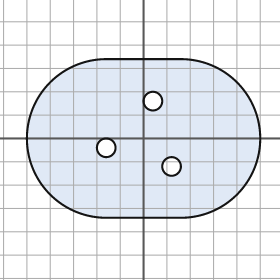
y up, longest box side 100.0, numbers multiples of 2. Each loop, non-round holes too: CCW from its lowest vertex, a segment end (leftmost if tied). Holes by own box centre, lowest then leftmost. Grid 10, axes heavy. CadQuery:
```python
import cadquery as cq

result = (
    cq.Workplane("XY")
    .moveTo(-16.0, -34.0)
    .lineTo(16.0, -34.0)
    .threePointArc((50.0, 0.0), (16.0, 34.0))
    .lineTo(-16.0, 34.0)
    .threePointArc((-50.0, 0.0), (-16.0, -34.0))
    .close()
    .moveTo(12.0, -12.0)
    .circle(4.0)
    .moveTo(-16.0, -4.0)
    .circle(4.0)
    .moveTo(4.0, 16.0)
    .circle(4.0)
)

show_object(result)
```